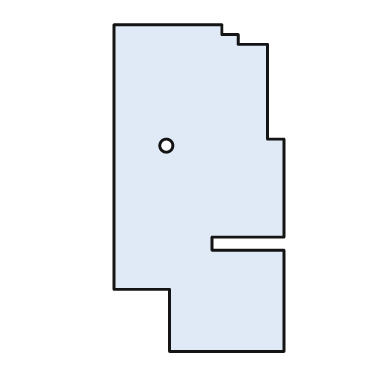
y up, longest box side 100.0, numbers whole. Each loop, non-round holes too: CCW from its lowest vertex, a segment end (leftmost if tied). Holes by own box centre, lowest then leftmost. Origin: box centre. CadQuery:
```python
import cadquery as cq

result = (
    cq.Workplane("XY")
    .moveTo(-9.0, -50.0)
    .lineTo(26.0, -50.0)
    .lineTo(26.0, -19.0)
    .lineTo(4.0, -19.0)
    .lineTo(4.0, -15.0)
    .lineTo(26.0, -15.0)
    .lineTo(26.0, 15.0)
    .lineTo(21.0, 15.0)
    .lineTo(21.0, 44.0)
    .lineTo(12.0, 44.0)
    .lineTo(12.0, 47.0)
    .lineTo(7.0, 47.0)
    .lineTo(7.0, 50.0)
    .lineTo(-26.0, 50.0)
    .lineTo(-26.0, -31.0)
    .lineTo(-9.0, -31.0)
    .close()
    .moveTo(-10.0, 13.0)
    .circle(2.0)
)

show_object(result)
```